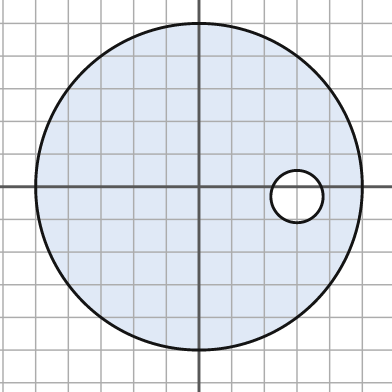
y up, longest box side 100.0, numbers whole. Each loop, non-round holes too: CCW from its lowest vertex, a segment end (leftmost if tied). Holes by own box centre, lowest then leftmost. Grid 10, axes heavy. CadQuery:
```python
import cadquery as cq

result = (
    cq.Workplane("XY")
    .moveTo(0.0, 0.0)
    .circle(50.0)
    .moveTo(30.0, -3.0)
    .circle(8.0)
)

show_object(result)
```